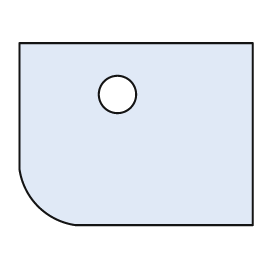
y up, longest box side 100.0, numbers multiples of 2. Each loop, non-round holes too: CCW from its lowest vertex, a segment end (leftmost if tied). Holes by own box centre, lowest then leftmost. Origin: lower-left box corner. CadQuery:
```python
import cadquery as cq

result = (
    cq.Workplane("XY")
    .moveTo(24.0, 0.0)
    .lineTo(100.0, 0.0)
    .lineTo(100.0, 78.0)
    .lineTo(0.0, 78.0)
    .lineTo(0.0, 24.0)
    .threePointArc((8.0, 8.0), (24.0, 0.0))
    .close()
    .moveTo(42.0, 56.0)
    .circle(8.0)
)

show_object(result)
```